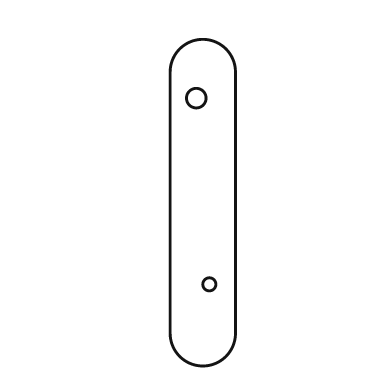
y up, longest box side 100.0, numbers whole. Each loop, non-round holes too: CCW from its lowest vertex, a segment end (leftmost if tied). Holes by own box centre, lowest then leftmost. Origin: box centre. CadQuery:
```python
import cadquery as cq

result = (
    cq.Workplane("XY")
    .moveTo(-10.0, -40.0)
    .threePointArc((0.0, -50.0), (10.0, -40.0))
    .lineTo(10.0, 40.0)
    .threePointArc((0.0, 50.0), (-10.0, 40.0))
    .close()
    .moveTo(2.0, -25.0)
    .circle(2.0)
    .moveTo(-2.0, 32.0)
    .circle(3.0)
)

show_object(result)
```